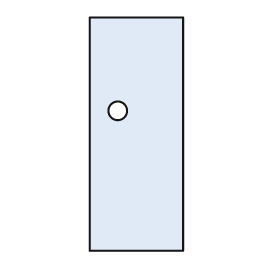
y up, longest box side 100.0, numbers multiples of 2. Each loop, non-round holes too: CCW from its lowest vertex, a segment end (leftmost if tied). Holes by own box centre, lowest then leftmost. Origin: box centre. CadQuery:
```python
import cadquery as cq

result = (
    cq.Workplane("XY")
    .moveTo(-20.0, -50.0)
    .lineTo(20.0, -50.0)
    .lineTo(20.0, 50.0)
    .lineTo(-20.0, 50.0)
    .close()
    .moveTo(-8.0, 10.0)
    .circle(4.0)
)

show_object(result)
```